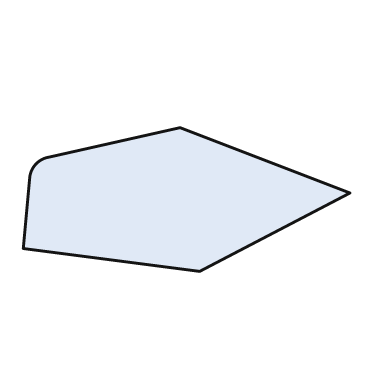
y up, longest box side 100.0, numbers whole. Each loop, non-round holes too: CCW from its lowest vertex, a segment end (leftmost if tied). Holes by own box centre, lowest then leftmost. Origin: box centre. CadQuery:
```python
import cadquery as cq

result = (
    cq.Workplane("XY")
    .moveTo(4.0, -22.0)
    .lineTo(50.0, 2.0)
    .lineTo(-2.0, 22.0)
    .lineTo(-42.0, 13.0)
    .threePointArc((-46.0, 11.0), (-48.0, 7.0))
    .lineTo(-50.0, -15.0)
    .close()
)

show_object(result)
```